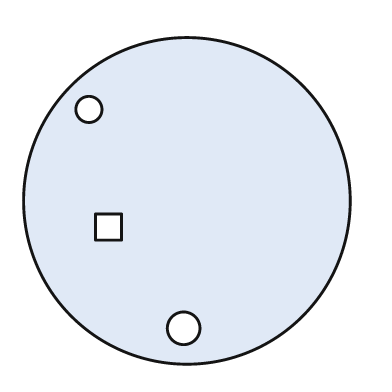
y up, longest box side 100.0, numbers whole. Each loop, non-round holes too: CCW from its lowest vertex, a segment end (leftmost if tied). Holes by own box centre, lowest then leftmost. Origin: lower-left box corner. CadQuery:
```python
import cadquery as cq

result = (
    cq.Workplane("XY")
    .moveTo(50.0, 50.0)
    .circle(50.0)
    .moveTo(49.0, 11.0)
    .circle(5.0)
    .moveTo(22.0, 38.0)
    .lineTo(30.0, 38.0)
    .lineTo(30.0, 46.0)
    .lineTo(22.0, 46.0)
    .close()
    .moveTo(20.0, 78.0)
    .circle(4.0)
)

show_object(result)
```